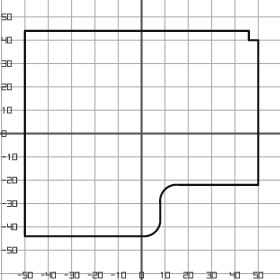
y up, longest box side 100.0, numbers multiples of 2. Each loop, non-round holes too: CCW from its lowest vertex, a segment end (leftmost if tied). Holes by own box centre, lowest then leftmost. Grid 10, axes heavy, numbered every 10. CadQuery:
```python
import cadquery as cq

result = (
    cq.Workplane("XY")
    .moveTo(-50.0, -44.0)
    .lineTo(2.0, -44.0)
    .threePointArc((6.0, -42.0), (8.0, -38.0))
    .lineTo(8.0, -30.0)
    .threePointArc((10.0, -24.0), (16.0, -22.0))
    .lineTo(50.0, -22.0)
    .lineTo(50.0, 40.0)
    .lineTo(46.0, 40.0)
    .lineTo(46.0, 44.0)
    .lineTo(-50.0, 44.0)
    .close()
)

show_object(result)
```